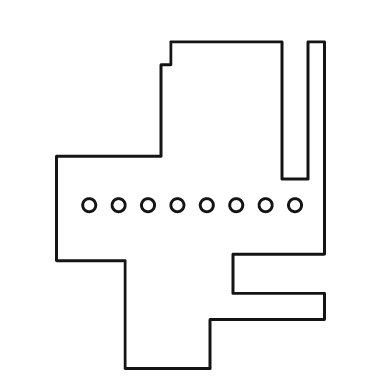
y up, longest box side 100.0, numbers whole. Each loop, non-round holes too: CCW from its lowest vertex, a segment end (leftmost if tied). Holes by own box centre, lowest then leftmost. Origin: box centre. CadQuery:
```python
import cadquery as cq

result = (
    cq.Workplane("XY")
    .moveTo(-20.0, -50.0)
    .lineTo(6.0, -50.0)
    .lineTo(6.0, -35.0)
    .lineTo(41.0, -35.0)
    .lineTo(41.0, -27.0)
    .lineTo(13.0, -27.0)
    .lineTo(13.0, -15.0)
    .lineTo(41.0, -15.0)
    .lineTo(41.0, 50.0)
    .lineTo(36.0, 50.0)
    .lineTo(36.0, 8.0)
    .lineTo(28.0, 8.0)
    .lineTo(28.0, 50.0)
    .lineTo(-6.0, 50.0)
    .lineTo(-6.0, 43.0)
    .lineTo(-9.0, 43.0)
    .lineTo(-9.0, 15.0)
    .lineTo(-41.0, 15.0)
    .lineTo(-41.0, -17.0)
    .lineTo(-20.0, -17.0)
    .close()
    .moveTo(-31.0, 0.0)
    .circle(2.0)
    .moveTo(-22.0, 0.0)
    .circle(2.0)
    .moveTo(-13.0, 0.0)
    .circle(2.0)
    .moveTo(-4.0, 0.0)
    .circle(2.0)
    .moveTo(5.0, 0.0)
    .circle(2.0)
    .moveTo(14.0, 0.0)
    .circle(2.0)
    .moveTo(23.0, 0.0)
    .circle(2.0)
    .moveTo(32.0, 0.0)
    .circle(2.0)
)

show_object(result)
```